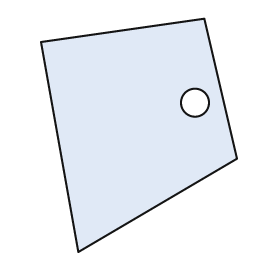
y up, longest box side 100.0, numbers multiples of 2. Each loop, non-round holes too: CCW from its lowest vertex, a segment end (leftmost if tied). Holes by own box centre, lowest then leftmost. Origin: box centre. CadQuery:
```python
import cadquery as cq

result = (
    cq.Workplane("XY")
    .moveTo(-26.0, -50.0)
    .lineTo(42.0, -10.0)
    .lineTo(28.0, 50.0)
    .lineTo(-42.0, 40.0)
    .close()
    .moveTo(24.0, 14.0)
    .circle(6.0)
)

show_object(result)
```